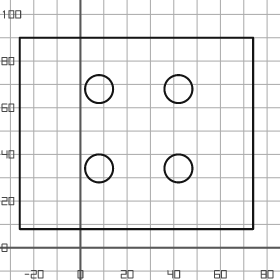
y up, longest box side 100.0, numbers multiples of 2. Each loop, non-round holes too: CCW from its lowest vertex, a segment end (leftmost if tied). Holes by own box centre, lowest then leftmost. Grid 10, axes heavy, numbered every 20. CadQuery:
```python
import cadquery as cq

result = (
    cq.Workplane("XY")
    .moveTo(-26.0, 8.0)
    .lineTo(74.0, 8.0)
    .lineTo(74.0, 90.0)
    .lineTo(-26.0, 90.0)
    .close()
    .moveTo(8.0, 34.0)
    .circle(6.0)
    .moveTo(42.0, 34.0)
    .circle(6.0)
    .moveTo(8.0, 68.0)
    .circle(6.0)
    .moveTo(42.0, 68.0)
    .circle(6.0)
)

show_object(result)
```